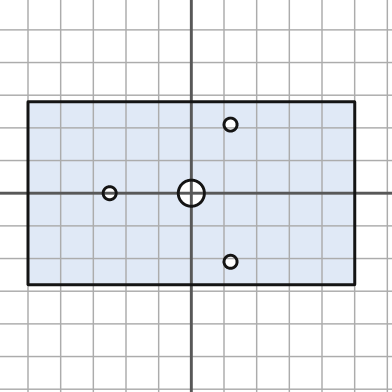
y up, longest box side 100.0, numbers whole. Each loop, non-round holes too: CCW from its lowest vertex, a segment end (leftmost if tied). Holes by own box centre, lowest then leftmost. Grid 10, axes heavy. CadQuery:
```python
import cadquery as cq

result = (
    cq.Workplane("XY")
    .moveTo(-50.0, -28.0)
    .lineTo(50.0, -28.0)
    .lineTo(50.0, 28.0)
    .lineTo(-50.0, 28.0)
    .close()
    .moveTo(12.0, -21.0)
    .circle(2.0)
    .moveTo(-25.0, 0.0)
    .circle(2.0)
    .moveTo(0.0, 0.0)
    .circle(4.0)
    .moveTo(12.0, 21.0)
    .circle(2.0)
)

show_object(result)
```